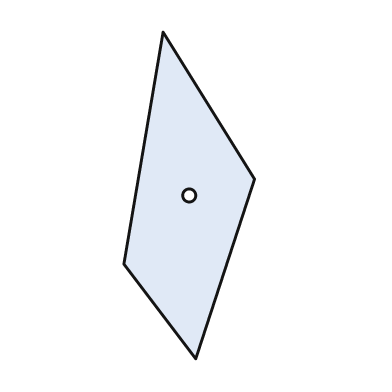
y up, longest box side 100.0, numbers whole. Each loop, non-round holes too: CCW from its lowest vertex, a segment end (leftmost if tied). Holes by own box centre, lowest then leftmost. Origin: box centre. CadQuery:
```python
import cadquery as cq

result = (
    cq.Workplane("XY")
    .moveTo(2.0, -50.0)
    .lineTo(20.0, 5.0)
    .lineTo(-8.0, 50.0)
    .lineTo(-20.0, -21.0)
    .close()
    .moveTo(0.0, 0.0)
    .circle(2.0)
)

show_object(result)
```